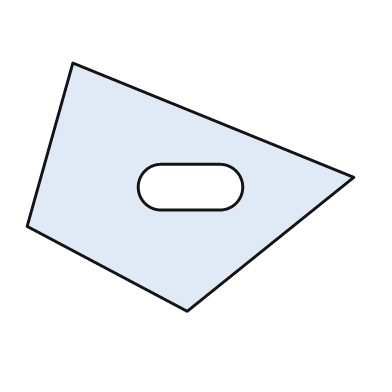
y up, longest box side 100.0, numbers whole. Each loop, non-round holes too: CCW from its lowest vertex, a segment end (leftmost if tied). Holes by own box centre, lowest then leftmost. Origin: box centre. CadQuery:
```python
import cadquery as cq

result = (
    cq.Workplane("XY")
    .moveTo(-1.0, -38.0)
    .lineTo(50.0, 3.0)
    .lineTo(-36.0, 38.0)
    .lineTo(-50.0, -12.0)
    .close()
    .moveTo(-9.0, -7.0)
    .lineTo(9.0, -7.0)
    .threePointArc((16.0, 0.0), (9.0, 7.0))
    .lineTo(-9.0, 7.0)
    .threePointArc((-16.0, 0.0), (-9.0, -7.0))
    .close()
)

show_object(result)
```